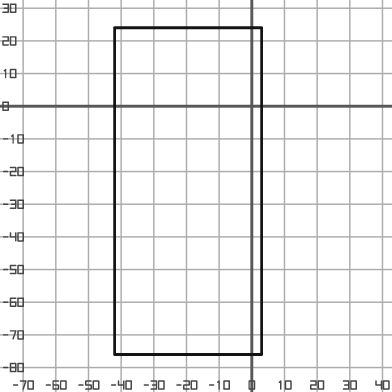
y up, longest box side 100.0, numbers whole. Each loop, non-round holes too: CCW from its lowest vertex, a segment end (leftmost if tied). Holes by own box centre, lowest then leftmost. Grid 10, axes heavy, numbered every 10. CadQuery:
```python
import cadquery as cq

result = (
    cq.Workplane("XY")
    .moveTo(-42.0, -76.0)
    .lineTo(3.0, -76.0)
    .lineTo(3.0, 24.0)
    .lineTo(-42.0, 24.0)
    .close()
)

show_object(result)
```